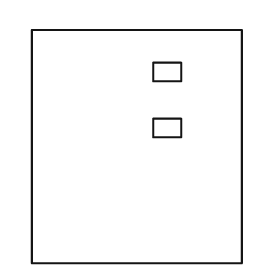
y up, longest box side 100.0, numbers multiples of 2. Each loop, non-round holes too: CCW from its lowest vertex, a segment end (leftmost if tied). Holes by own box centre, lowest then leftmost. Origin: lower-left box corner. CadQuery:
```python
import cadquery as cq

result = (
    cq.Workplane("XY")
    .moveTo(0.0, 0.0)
    .lineTo(90.0, 0.0)
    .lineTo(90.0, 100.0)
    .lineTo(0.0, 100.0)
    .close()
    .moveTo(52.0, 54.0)
    .lineTo(64.0, 54.0)
    .lineTo(64.0, 62.0)
    .lineTo(52.0, 62.0)
    .close()
    .moveTo(52.0, 78.0)
    .lineTo(64.0, 78.0)
    .lineTo(64.0, 86.0)
    .lineTo(52.0, 86.0)
    .close()
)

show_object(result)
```